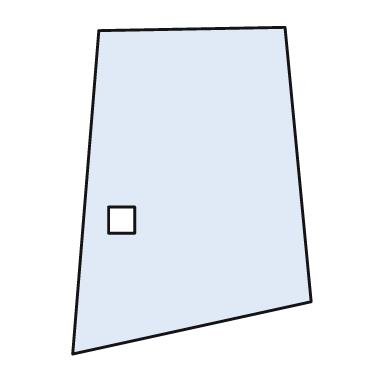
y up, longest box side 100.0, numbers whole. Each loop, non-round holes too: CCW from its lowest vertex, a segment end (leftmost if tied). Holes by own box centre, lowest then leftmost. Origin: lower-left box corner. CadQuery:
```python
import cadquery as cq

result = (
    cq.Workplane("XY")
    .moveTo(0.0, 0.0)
    .lineTo(73.0, 16.0)
    .lineTo(65.0, 100.0)
    .lineTo(8.0, 99.0)
    .close()
    .moveTo(11.0, 37.0)
    .lineTo(19.0, 37.0)
    .lineTo(19.0, 45.0)
    .lineTo(11.0, 45.0)
    .close()
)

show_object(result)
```